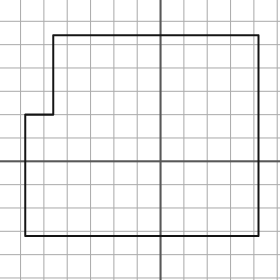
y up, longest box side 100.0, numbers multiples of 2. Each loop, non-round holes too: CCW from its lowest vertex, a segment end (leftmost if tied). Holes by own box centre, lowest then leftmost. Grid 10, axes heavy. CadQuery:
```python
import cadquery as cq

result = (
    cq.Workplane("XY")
    .moveTo(-58.0, -32.0)
    .lineTo(42.0, -32.0)
    .lineTo(42.0, 54.0)
    .lineTo(-46.0, 54.0)
    .lineTo(-46.0, 20.0)
    .lineTo(-58.0, 20.0)
    .close()
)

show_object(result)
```